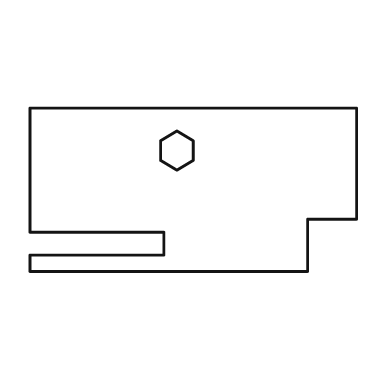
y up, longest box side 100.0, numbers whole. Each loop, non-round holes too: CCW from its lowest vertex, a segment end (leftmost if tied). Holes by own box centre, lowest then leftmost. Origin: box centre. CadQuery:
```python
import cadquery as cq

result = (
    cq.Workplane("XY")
    .moveTo(-50.0, -25.0)
    .lineTo(35.0, -25.0)
    .lineTo(35.0, -9.0)
    .lineTo(50.0, -9.0)
    .lineTo(50.0, 25.0)
    .lineTo(-50.0, 25.0)
    .lineTo(-50.0, -13.0)
    .lineTo(-9.0, -13.0)
    .lineTo(-9.0, -20.0)
    .lineTo(-50.0, -20.0)
    .close()
    .moveTo(-5.0, 6.0)
    .lineTo(0.0, 9.0)
    .lineTo(0.0, 15.0)
    .lineTo(-5.0, 18.0)
    .lineTo(-10.0, 15.0)
    .lineTo(-10.0, 9.0)
    .close()
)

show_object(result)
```